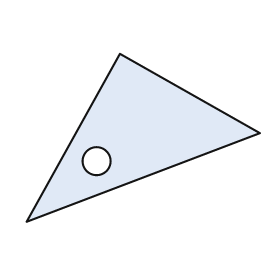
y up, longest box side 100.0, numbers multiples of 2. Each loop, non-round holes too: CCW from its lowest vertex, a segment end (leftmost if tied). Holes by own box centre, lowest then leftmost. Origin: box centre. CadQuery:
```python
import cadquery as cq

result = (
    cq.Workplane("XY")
    .moveTo(-50.0, -36.0)
    .lineTo(50.0, 2.0)
    .lineTo(-10.0, 36.0)
    .close()
    .moveTo(-20.0, -10.0)
    .circle(6.0)
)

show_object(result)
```